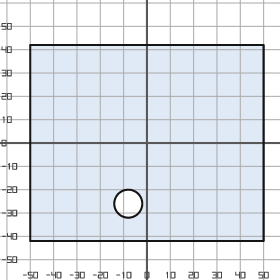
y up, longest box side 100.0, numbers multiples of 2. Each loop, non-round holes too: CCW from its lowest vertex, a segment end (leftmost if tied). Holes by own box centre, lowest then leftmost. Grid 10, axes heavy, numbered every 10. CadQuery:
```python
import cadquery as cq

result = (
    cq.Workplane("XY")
    .moveTo(-50.0, -42.0)
    .lineTo(50.0, -42.0)
    .lineTo(50.0, 42.0)
    .lineTo(-50.0, 42.0)
    .close()
    .moveTo(-8.0, -26.0)
    .circle(6.0)
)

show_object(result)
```